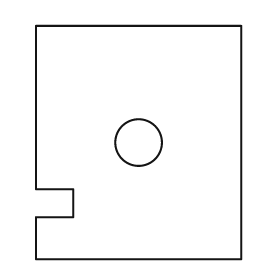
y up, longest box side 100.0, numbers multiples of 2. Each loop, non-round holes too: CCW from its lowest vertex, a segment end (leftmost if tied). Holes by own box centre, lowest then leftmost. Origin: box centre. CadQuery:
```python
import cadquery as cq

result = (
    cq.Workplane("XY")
    .moveTo(-44.0, -50.0)
    .lineTo(44.0, -50.0)
    .lineTo(44.0, 50.0)
    .lineTo(-44.0, 50.0)
    .lineTo(-44.0, -20.0)
    .lineTo(-28.0, -20.0)
    .lineTo(-28.0, -32.0)
    .lineTo(-44.0, -32.0)
    .close()
    .moveTo(0.0, 0.0)
    .circle(10.0)
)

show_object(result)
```